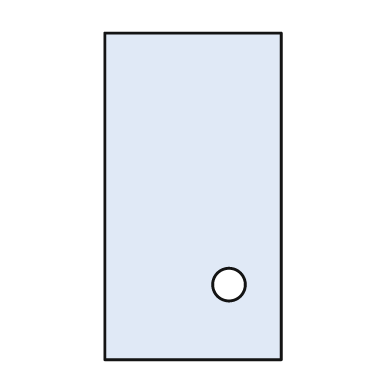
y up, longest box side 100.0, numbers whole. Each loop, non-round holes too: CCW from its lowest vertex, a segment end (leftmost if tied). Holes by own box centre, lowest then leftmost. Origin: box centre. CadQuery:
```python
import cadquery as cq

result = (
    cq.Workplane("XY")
    .moveTo(-27.0, -50.0)
    .lineTo(27.0, -50.0)
    .lineTo(27.0, 50.0)
    .lineTo(-27.0, 50.0)
    .close()
    .moveTo(11.0, -27.0)
    .circle(5.0)
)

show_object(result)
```